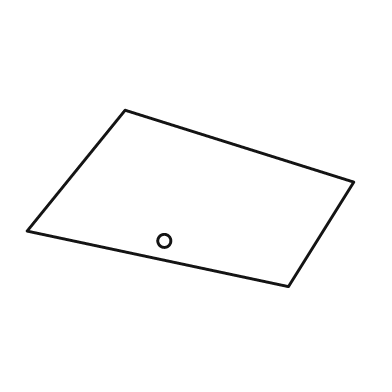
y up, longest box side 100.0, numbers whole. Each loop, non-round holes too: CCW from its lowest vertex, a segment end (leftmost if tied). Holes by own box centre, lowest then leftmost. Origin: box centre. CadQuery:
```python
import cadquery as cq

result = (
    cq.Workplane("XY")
    .moveTo(30.0, -27.0)
    .lineTo(50.0, 5.0)
    .lineTo(-20.0, 27.0)
    .lineTo(-50.0, -10.0)
    .close()
    .moveTo(-8.0, -13.0)
    .circle(2.0)
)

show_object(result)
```